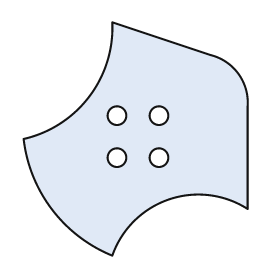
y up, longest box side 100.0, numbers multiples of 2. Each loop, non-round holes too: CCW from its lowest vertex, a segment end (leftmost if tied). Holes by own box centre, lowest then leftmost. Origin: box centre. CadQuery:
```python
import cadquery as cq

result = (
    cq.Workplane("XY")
    .moveTo(-10.0, -50.0)
    .threePointArc((14.0, -26.0), (48.0, -30.0))
    .lineTo(48.0, 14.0)
    .threePointArc((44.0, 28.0), (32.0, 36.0))
    .lineTo(-10.0, 50.0)
    .threePointArc((-20.0, 18.0), (-48.0, 0.0))
    .threePointArc((-36.0, -30.0), (-10.0, -50.0))
    .close()
    .moveTo(-8.0, -8.0)
    .circle(4.0)
    .moveTo(10.0, -8.0)
    .circle(4.0)
    .moveTo(-8.0, 10.0)
    .circle(4.0)
    .moveTo(10.0, 10.0)
    .circle(4.0)
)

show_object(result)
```